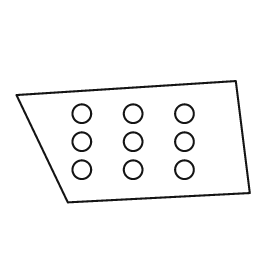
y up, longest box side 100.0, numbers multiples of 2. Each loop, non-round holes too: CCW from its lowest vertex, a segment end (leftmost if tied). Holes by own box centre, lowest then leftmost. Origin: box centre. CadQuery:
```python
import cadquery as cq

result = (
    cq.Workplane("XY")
    .moveTo(-28.0, -26.0)
    .lineTo(50.0, -22.0)
    .lineTo(44.0, 26.0)
    .lineTo(-50.0, 20.0)
    .close()
    .moveTo(-22.0, -12.0)
    .circle(4.0)
    .moveTo(0.0, -12.0)
    .circle(4.0)
    .moveTo(22.0, -12.0)
    .circle(4.0)
    .moveTo(-22.0, 0.0)
    .circle(4.0)
    .moveTo(0.0, 0.0)
    .circle(4.0)
    .moveTo(22.0, 0.0)
    .circle(4.0)
    .moveTo(-22.0, 12.0)
    .circle(4.0)
    .moveTo(0.0, 12.0)
    .circle(4.0)
    .moveTo(22.0, 12.0)
    .circle(4.0)
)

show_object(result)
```